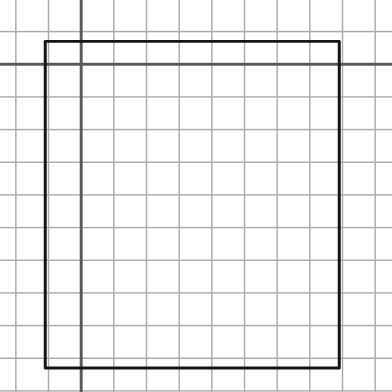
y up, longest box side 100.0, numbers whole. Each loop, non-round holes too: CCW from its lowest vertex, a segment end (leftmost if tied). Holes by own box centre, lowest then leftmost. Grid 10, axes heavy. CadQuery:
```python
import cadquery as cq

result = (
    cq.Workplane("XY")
    .moveTo(-11.0, -93.0)
    .lineTo(79.0, -93.0)
    .lineTo(79.0, 7.0)
    .lineTo(-11.0, 7.0)
    .close()
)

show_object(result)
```